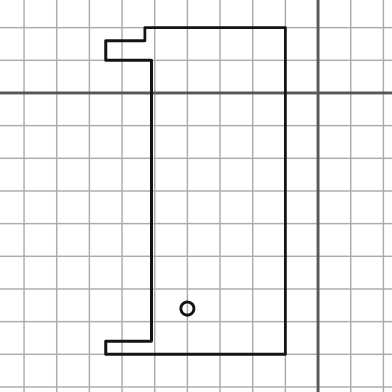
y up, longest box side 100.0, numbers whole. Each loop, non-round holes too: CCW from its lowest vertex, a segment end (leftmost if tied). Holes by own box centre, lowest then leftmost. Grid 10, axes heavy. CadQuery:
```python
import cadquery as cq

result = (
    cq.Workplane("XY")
    .moveTo(-65.0, -80.0)
    .lineTo(-10.0, -80.0)
    .lineTo(-10.0, 20.0)
    .lineTo(-53.0, 20.0)
    .lineTo(-53.0, 16.0)
    .lineTo(-65.0, 16.0)
    .lineTo(-65.0, 10.0)
    .lineTo(-51.0, 10.0)
    .lineTo(-51.0, -76.0)
    .lineTo(-65.0, -76.0)
    .close()
    .moveTo(-40.0, -66.0)
    .circle(2.0)
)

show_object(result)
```